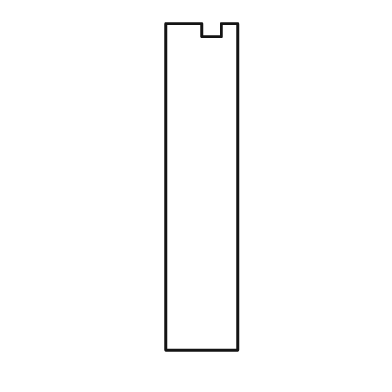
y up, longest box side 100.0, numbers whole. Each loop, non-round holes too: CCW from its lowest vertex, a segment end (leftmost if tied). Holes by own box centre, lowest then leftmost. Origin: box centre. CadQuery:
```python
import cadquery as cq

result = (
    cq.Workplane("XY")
    .moveTo(-11.0, -50.0)
    .lineTo(11.0, -50.0)
    .lineTo(11.0, 50.0)
    .lineTo(6.0, 50.0)
    .lineTo(6.0, 46.0)
    .lineTo(0.0, 46.0)
    .lineTo(0.0, 50.0)
    .lineTo(-11.0, 50.0)
    .close()
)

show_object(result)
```